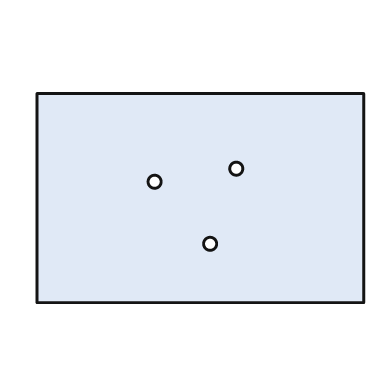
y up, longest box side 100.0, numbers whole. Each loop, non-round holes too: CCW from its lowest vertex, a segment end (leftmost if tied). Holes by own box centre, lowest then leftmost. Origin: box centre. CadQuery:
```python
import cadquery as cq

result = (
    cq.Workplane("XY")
    .moveTo(-50.0, -32.0)
    .lineTo(50.0, -32.0)
    .lineTo(50.0, 32.0)
    .lineTo(-50.0, 32.0)
    .close()
    .moveTo(3.0, -14.0)
    .circle(2.0)
    .moveTo(-14.0, 5.0)
    .circle(2.0)
    .moveTo(11.0, 9.0)
    .circle(2.0)
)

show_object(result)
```